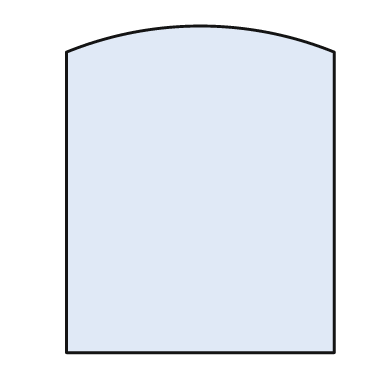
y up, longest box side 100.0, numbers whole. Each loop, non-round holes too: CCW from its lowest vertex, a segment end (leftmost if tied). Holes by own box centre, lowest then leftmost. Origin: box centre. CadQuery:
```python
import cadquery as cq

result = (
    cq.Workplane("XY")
    .moveTo(-41.0, -50.0)
    .lineTo(41.0, -50.0)
    .lineTo(41.0, 42.0)
    .threePointArc((0.0, 50.0), (-41.0, 42.0))
    .close()
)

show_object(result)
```